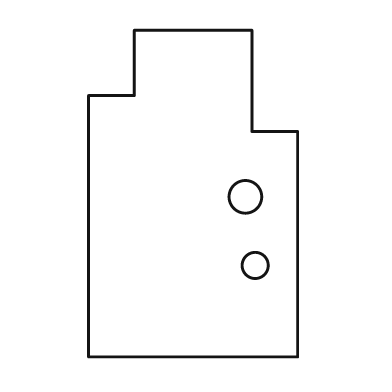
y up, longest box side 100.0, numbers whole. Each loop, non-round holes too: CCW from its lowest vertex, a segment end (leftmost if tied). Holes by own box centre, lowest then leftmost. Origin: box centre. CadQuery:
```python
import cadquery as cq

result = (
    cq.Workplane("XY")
    .moveTo(-32.0, -50.0)
    .lineTo(32.0, -50.0)
    .lineTo(32.0, 19.0)
    .lineTo(18.0, 19.0)
    .lineTo(18.0, 50.0)
    .lineTo(-18.0, 50.0)
    .lineTo(-18.0, 30.0)
    .lineTo(-32.0, 30.0)
    .close()
    .moveTo(19.0, -22.0)
    .circle(4.0)
    .moveTo(16.0, -1.0)
    .circle(5.0)
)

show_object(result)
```